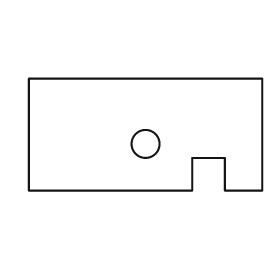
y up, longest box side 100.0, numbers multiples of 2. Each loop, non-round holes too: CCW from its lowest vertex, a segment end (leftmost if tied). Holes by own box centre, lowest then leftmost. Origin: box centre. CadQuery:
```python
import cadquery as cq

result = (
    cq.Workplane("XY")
    .moveTo(-50.0, -24.0)
    .lineTo(20.0, -24.0)
    .lineTo(20.0, -10.0)
    .lineTo(34.0, -10.0)
    .lineTo(34.0, -24.0)
    .lineTo(50.0, -24.0)
    .lineTo(50.0, 24.0)
    .lineTo(-50.0, 24.0)
    .close()
    .moveTo(0.0, -4.0)
    .circle(6.0)
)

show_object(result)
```